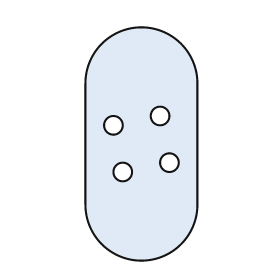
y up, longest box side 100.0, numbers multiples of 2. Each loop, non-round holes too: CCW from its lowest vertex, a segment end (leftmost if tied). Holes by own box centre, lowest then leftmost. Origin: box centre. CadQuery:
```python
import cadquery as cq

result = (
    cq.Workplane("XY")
    .moveTo(-24.0, -26.0)
    .threePointArc((0.0, -50.0), (24.0, -26.0))
    .lineTo(24.0, 26.0)
    .threePointArc((0.0, 50.0), (-24.0, 26.0))
    .close()
    .moveTo(-8.0, -12.0)
    .circle(4.0)
    .moveTo(12.0, -8.0)
    .circle(4.0)
    .moveTo(-12.0, 8.0)
    .circle(4.0)
    .moveTo(8.0, 12.0)
    .circle(4.0)
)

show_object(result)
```